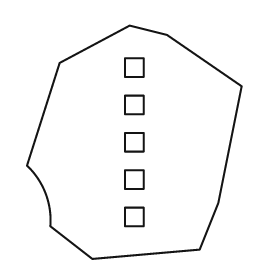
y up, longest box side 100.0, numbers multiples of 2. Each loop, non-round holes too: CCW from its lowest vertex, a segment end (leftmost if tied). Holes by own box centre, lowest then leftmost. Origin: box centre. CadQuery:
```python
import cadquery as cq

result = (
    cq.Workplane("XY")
    .moveTo(-18.0, -50.0)
    .lineTo(28.0, -46.0)
    .lineTo(36.0, -26.0)
    .lineTo(46.0, 24.0)
    .lineTo(14.0, 46.0)
    .lineTo(-2.0, 50.0)
    .lineTo(-32.0, 34.0)
    .lineTo(-46.0, -10.0)
    .threePointArc((-38.0, -22.0), (-36.0, -36.0))
    .close()
    .moveTo(-4.0, -36.0)
    .lineTo(4.0, -36.0)
    .lineTo(4.0, -28.0)
    .lineTo(-4.0, -28.0)
    .close()
    .moveTo(-4.0, -20.0)
    .lineTo(4.0, -20.0)
    .lineTo(4.0, -12.0)
    .lineTo(-4.0, -12.0)
    .close()
    .moveTo(-4.0, -4.0)
    .lineTo(4.0, -4.0)
    .lineTo(4.0, 4.0)
    .lineTo(-4.0, 4.0)
    .close()
    .moveTo(-4.0, 12.0)
    .lineTo(4.0, 12.0)
    .lineTo(4.0, 20.0)
    .lineTo(-4.0, 20.0)
    .close()
    .moveTo(-4.0, 28.0)
    .lineTo(4.0, 28.0)
    .lineTo(4.0, 36.0)
    .lineTo(-4.0, 36.0)
    .close()
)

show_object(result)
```